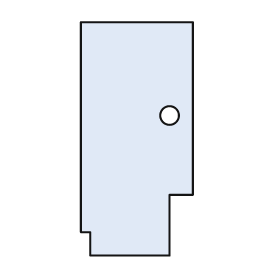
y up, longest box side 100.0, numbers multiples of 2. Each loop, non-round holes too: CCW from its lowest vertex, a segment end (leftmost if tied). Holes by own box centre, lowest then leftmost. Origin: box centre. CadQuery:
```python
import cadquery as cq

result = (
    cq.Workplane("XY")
    .moveTo(-20.0, -50.0)
    .lineTo(14.0, -50.0)
    .lineTo(14.0, -24.0)
    .lineTo(24.0, -24.0)
    .lineTo(24.0, 50.0)
    .lineTo(-24.0, 50.0)
    .lineTo(-24.0, -40.0)
    .lineTo(-20.0, -40.0)
    .close()
    .moveTo(14.0, 10.0)
    .circle(4.0)
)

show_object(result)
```